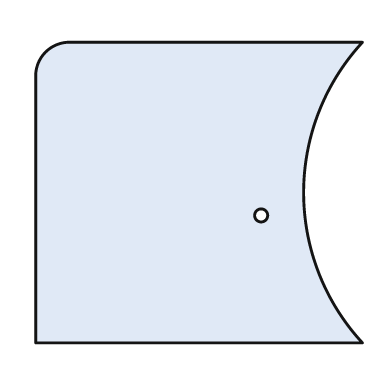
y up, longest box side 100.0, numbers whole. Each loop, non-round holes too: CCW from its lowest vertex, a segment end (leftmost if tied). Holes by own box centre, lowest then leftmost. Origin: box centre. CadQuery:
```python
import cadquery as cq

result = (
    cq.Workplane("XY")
    .moveTo(-50.0, -46.0)
    .lineTo(50.0, -46.0)
    .threePointArc((32.0, 0.0), (50.0, 46.0))
    .lineTo(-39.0, 46.0)
    .threePointArc((-47.0, 43.0), (-50.0, 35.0))
    .close()
    .moveTo(19.0, -7.0)
    .circle(2.0)
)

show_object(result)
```